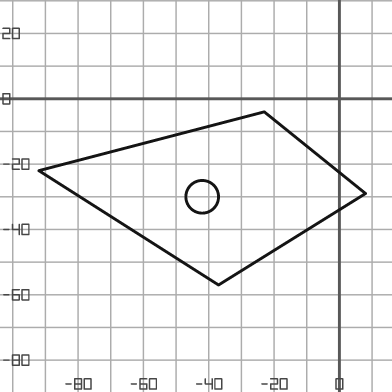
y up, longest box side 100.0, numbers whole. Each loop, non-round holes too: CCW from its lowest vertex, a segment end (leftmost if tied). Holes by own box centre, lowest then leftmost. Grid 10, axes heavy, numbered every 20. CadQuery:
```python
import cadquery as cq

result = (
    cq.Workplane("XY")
    .moveTo(-37.0, -57.0)
    .lineTo(8.0, -29.0)
    .lineTo(-23.0, -4.0)
    .lineTo(-92.0, -22.0)
    .close()
    .moveTo(-42.0, -30.0)
    .circle(5.0)
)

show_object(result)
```